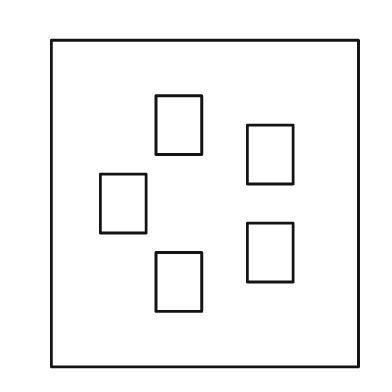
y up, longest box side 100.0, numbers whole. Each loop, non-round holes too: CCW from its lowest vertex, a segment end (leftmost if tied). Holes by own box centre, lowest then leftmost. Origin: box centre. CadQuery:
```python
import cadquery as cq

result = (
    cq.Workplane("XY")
    .moveTo(-47.0, -50.0)
    .lineTo(47.0, -50.0)
    .lineTo(47.0, 50.0)
    .lineTo(-47.0, 50.0)
    .close()
    .moveTo(-15.0, -33.0)
    .lineTo(-1.0, -33.0)
    .lineTo(-1.0, -15.0)
    .lineTo(-15.0, -15.0)
    .close()
    .moveTo(13.0, -24.0)
    .lineTo(27.0, -24.0)
    .lineTo(27.0, -6.0)
    .lineTo(13.0, -6.0)
    .close()
    .moveTo(-32.0, -9.0)
    .lineTo(-18.0, -9.0)
    .lineTo(-18.0, 9.0)
    .lineTo(-32.0, 9.0)
    .close()
    .moveTo(13.0, 6.0)
    .lineTo(27.0, 6.0)
    .lineTo(27.0, 24.0)
    .lineTo(13.0, 24.0)
    .close()
    .moveTo(-15.0, 15.0)
    .lineTo(-1.0, 15.0)
    .lineTo(-1.0, 33.0)
    .lineTo(-15.0, 33.0)
    .close()
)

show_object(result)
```